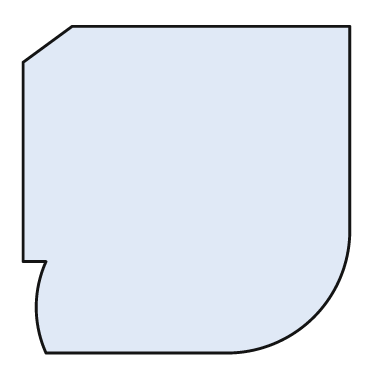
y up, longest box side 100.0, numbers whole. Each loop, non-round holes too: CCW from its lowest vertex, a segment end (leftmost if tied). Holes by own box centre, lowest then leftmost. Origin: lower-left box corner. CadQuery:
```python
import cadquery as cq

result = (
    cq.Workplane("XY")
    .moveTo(7.0, 0.0)
    .lineTo(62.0, 0.0)
    .threePointArc((89.0, 11.0), (100.0, 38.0))
    .lineTo(100.0, 100.0)
    .lineTo(15.0, 100.0)
    .lineTo(0.0, 89.0)
    .lineTo(0.0, 28.0)
    .lineTo(7.0, 28.0)
    .threePointArc((4.0, 14.0), (7.0, 0.0))
    .close()
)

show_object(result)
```